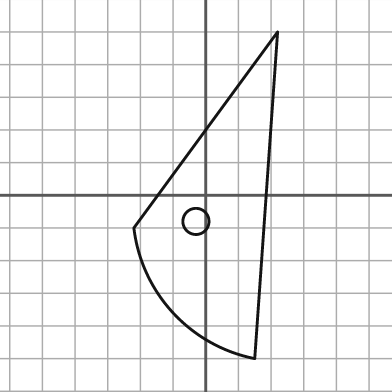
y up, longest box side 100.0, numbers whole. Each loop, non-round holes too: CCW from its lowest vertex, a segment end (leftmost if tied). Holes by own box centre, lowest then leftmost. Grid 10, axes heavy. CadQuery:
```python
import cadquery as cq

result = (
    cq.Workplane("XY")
    .moveTo(15.0, -50.0)
    .lineTo(22.0, 50.0)
    .lineTo(-22.0, -10.0)
    .threePointArc((-10.0, -36.0), (15.0, -50.0))
    .close()
    .moveTo(-3.0, -8.0)
    .circle(4.0)
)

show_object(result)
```